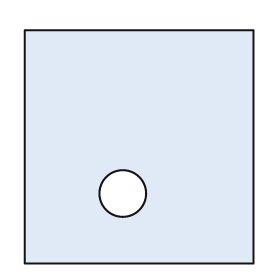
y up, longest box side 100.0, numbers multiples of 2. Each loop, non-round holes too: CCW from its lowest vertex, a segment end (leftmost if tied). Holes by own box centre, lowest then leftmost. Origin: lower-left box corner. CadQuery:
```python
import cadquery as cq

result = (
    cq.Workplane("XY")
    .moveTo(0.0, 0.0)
    .lineTo(98.0, 0.0)
    .lineTo(98.0, 100.0)
    .lineTo(0.0, 100.0)
    .close()
    .moveTo(42.0, 30.0)
    .circle(10.0)
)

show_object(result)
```